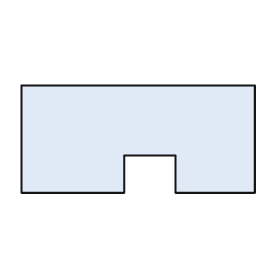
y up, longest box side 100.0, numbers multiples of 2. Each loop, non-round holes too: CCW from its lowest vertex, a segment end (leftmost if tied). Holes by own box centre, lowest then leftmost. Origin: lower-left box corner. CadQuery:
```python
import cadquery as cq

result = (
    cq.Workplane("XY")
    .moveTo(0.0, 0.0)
    .lineTo(44.0, 0.0)
    .lineTo(44.0, 16.0)
    .lineTo(66.0, 16.0)
    .lineTo(66.0, 0.0)
    .lineTo(100.0, 0.0)
    .lineTo(100.0, 46.0)
    .lineTo(0.0, 46.0)
    .close()
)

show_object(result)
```